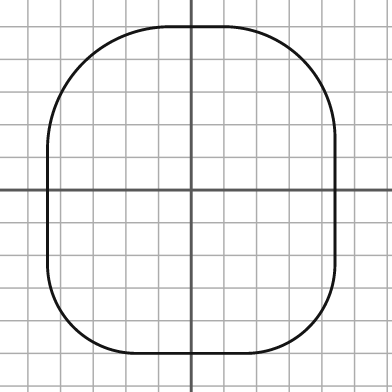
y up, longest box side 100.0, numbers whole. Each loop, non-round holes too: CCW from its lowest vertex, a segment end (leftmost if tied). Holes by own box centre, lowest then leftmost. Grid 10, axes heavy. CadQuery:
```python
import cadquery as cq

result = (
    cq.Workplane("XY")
    .moveTo(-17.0, -50.0)
    .lineTo(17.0, -50.0)
    .threePointArc((36.0, -42.0), (44.0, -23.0))
    .lineTo(44.0, 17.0)
    .threePointArc((34.0, 40.0), (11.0, 50.0))
    .lineTo(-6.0, 50.0)
    .threePointArc((-33.0, 39.0), (-44.0, 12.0))
    .lineTo(-44.0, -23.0)
    .threePointArc((-36.0, -42.0), (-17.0, -50.0))
    .close()
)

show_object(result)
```